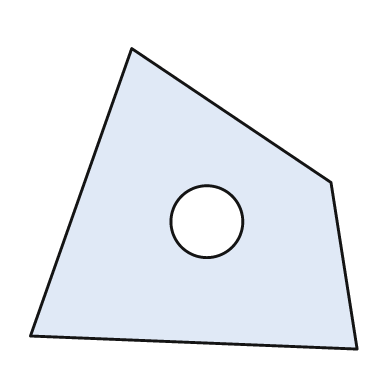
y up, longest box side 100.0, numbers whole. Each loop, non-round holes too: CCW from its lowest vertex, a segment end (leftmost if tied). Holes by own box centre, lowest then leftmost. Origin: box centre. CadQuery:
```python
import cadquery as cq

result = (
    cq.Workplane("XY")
    .moveTo(50.0, -46.0)
    .lineTo(42.0, 5.0)
    .lineTo(-19.0, 46.0)
    .lineTo(-50.0, -42.0)
    .close()
    .moveTo(4.0, -7.0)
    .circle(11.0)
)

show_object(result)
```